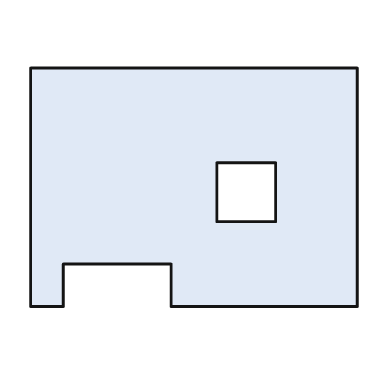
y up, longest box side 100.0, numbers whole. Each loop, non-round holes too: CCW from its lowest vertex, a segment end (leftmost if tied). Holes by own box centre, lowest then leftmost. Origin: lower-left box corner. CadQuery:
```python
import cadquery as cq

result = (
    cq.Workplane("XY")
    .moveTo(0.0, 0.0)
    .lineTo(10.0, 0.0)
    .lineTo(10.0, 13.0)
    .lineTo(43.0, 13.0)
    .lineTo(43.0, 0.0)
    .lineTo(100.0, 0.0)
    .lineTo(100.0, 73.0)
    .lineTo(0.0, 73.0)
    .close()
    .moveTo(57.0, 26.0)
    .lineTo(75.0, 26.0)
    .lineTo(75.0, 44.0)
    .lineTo(57.0, 44.0)
    .close()
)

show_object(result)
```